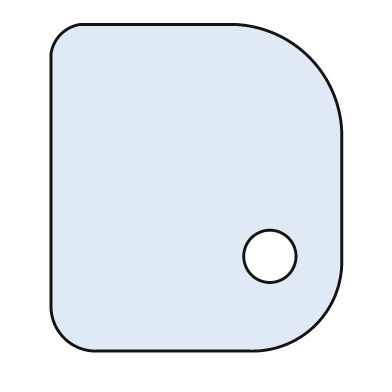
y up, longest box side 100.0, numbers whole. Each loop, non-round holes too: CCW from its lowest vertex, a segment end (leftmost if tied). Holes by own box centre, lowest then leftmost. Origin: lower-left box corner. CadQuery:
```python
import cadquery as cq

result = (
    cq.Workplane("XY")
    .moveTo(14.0, 0.0)
    .lineTo(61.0, 0.0)
    .threePointArc((81.0, 8.0), (89.0, 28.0))
    .lineTo(89.0, 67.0)
    .threePointArc((79.0, 90.0), (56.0, 100.0))
    .lineTo(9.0, 100.0)
    .threePointArc((3.0, 97.0), (0.0, 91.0))
    .lineTo(0.0, 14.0)
    .threePointArc((4.0, 4.0), (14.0, 0.0))
    .close()
    .moveTo(67.0, 29.0)
    .circle(8.0)
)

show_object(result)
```